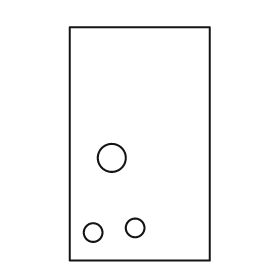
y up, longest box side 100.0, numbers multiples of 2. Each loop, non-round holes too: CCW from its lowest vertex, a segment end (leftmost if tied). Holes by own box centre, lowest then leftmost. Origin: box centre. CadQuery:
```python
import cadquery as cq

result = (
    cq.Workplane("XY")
    .moveTo(-30.0, -50.0)
    .lineTo(30.0, -50.0)
    .lineTo(30.0, 50.0)
    .lineTo(-30.0, 50.0)
    .close()
    .moveTo(-20.0, -38.0)
    .circle(4.0)
    .moveTo(-2.0, -36.0)
    .circle(4.0)
    .moveTo(-12.0, -6.0)
    .circle(6.0)
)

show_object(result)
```